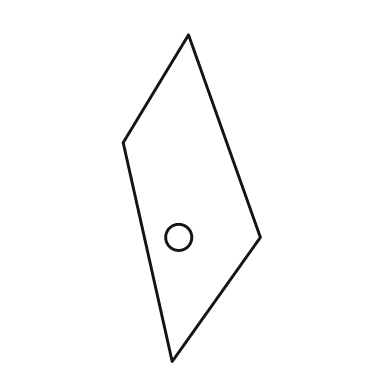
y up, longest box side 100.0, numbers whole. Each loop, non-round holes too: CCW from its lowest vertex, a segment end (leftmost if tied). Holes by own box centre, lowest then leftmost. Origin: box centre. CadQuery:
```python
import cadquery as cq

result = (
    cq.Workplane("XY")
    .moveTo(-6.0, -50.0)
    .lineTo(21.0, -12.0)
    .lineTo(-1.0, 50.0)
    .lineTo(-21.0, 17.0)
    .close()
    .moveTo(-4.0, -12.0)
    .circle(4.0)
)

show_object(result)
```